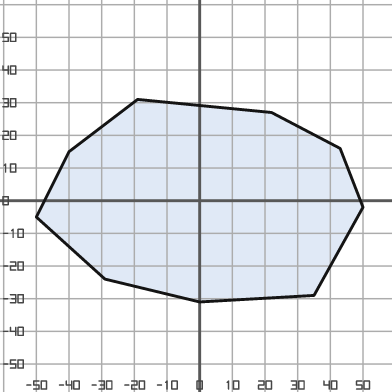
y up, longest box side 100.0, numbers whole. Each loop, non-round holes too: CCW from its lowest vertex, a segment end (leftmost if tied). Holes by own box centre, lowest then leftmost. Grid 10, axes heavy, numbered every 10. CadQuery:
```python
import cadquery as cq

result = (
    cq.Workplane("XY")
    .moveTo(0.0, -31.0)
    .lineTo(35.0, -29.0)
    .lineTo(50.0, -2.0)
    .lineTo(43.0, 16.0)
    .lineTo(22.0, 27.0)
    .lineTo(-19.0, 31.0)
    .lineTo(-40.0, 15.0)
    .lineTo(-50.0, -5.0)
    .lineTo(-29.0, -24.0)
    .close()
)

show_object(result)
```